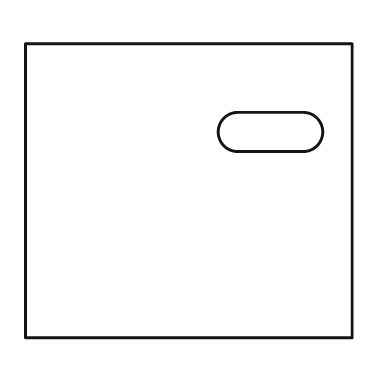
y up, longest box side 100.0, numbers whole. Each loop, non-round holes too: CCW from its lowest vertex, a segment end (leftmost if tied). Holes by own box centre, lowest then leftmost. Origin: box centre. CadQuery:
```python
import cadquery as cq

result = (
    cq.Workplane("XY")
    .moveTo(-50.0, -45.0)
    .lineTo(50.0, -45.0)
    .lineTo(50.0, 45.0)
    .lineTo(-50.0, 45.0)
    .close()
    .moveTo(15.0, 12.0)
    .lineTo(35.0, 12.0)
    .threePointArc((41.0, 18.0), (35.0, 24.0))
    .lineTo(15.0, 24.0)
    .threePointArc((9.0, 18.0), (15.0, 12.0))
    .close()
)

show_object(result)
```